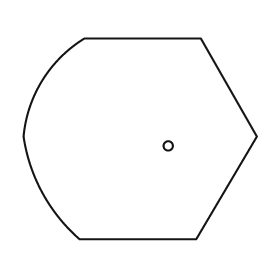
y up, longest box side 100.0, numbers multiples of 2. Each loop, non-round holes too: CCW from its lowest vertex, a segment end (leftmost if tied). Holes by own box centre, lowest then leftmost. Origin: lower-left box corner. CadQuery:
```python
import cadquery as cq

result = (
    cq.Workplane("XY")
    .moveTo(24.0, 0.0)
    .lineTo(74.0, 0.0)
    .lineTo(100.0, 44.0)
    .lineTo(76.0, 86.0)
    .lineTo(26.0, 86.0)
    .threePointArc((8.0, 68.0), (0.0, 44.0))
    .threePointArc((8.0, 20.0), (24.0, 0.0))
    .close()
    .moveTo(62.0, 40.0)
    .circle(2.0)
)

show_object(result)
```